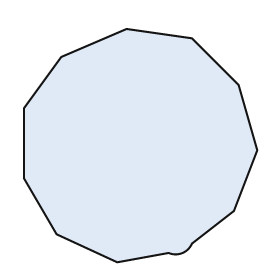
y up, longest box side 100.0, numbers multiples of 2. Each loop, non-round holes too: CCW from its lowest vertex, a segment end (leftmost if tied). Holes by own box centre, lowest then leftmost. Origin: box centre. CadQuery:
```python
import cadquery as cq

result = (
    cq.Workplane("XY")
    .moveTo(-10.0, -50.0)
    .lineTo(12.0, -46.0)
    .threePointArc((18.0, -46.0), (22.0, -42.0))
    .lineTo(40.0, -28.0)
    .lineTo(50.0, -2.0)
    .lineTo(42.0, 26.0)
    .lineTo(22.0, 46.0)
    .lineTo(-6.0, 50.0)
    .lineTo(-34.0, 38.0)
    .lineTo(-50.0, 16.0)
    .lineTo(-50.0, -14.0)
    .lineTo(-36.0, -38.0)
    .close()
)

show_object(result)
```